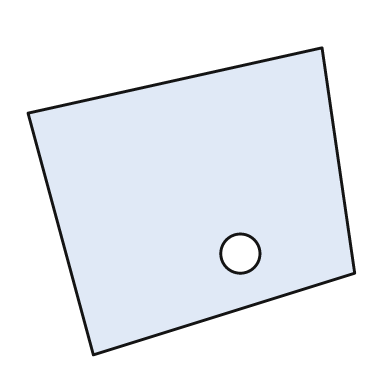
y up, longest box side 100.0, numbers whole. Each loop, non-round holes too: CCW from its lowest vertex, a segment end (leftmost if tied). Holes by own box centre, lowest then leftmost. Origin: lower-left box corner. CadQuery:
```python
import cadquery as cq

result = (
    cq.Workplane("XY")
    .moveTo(20.0, 0.0)
    .lineTo(100.0, 25.0)
    .lineTo(90.0, 94.0)
    .lineTo(0.0, 74.0)
    .close()
    .moveTo(65.0, 31.0)
    .circle(6.0)
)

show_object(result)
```